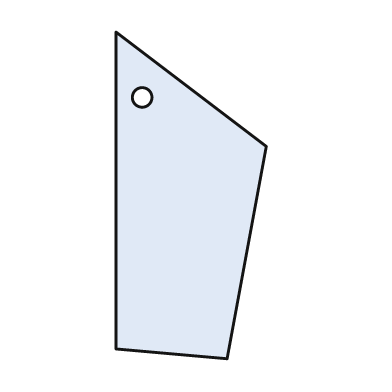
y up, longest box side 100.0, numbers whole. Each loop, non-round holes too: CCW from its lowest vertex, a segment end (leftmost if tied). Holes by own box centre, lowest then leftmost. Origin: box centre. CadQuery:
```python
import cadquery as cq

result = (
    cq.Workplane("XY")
    .moveTo(11.0, -50.0)
    .lineTo(23.0, 15.0)
    .lineTo(-23.0, 50.0)
    .lineTo(-23.0, -47.0)
    .close()
    .moveTo(-15.0, 30.0)
    .circle(3.0)
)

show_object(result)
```